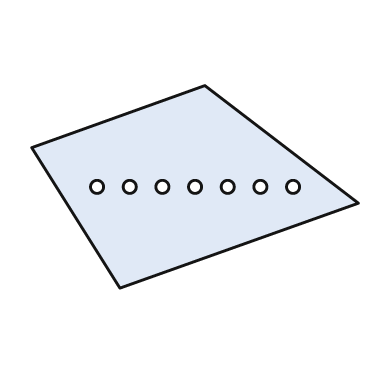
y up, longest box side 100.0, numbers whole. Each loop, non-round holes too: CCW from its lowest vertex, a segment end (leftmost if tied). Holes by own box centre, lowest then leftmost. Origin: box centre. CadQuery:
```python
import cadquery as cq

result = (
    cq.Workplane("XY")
    .moveTo(-23.0, -31.0)
    .lineTo(50.0, -5.0)
    .lineTo(3.0, 31.0)
    .lineTo(-50.0, 12.0)
    .close()
    .moveTo(-30.0, 0.0)
    .circle(2.0)
    .moveTo(-20.0, 0.0)
    .circle(2.0)
    .moveTo(-10.0, 0.0)
    .circle(2.0)
    .moveTo(0.0, 0.0)
    .circle(2.0)
    .moveTo(10.0, 0.0)
    .circle(2.0)
    .moveTo(20.0, 0.0)
    .circle(2.0)
    .moveTo(30.0, 0.0)
    .circle(2.0)
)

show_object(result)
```